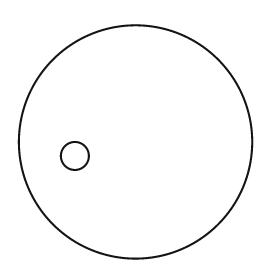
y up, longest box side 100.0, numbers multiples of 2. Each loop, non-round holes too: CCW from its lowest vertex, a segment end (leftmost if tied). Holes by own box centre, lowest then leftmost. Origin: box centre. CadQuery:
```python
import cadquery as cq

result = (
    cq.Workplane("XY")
    .moveTo(0.0, 0.0)
    .circle(50.0)
    .moveTo(-26.0, -6.0)
    .circle(6.0)
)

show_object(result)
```